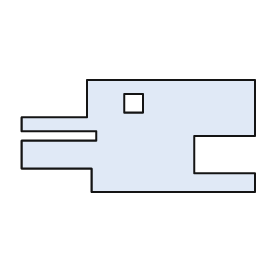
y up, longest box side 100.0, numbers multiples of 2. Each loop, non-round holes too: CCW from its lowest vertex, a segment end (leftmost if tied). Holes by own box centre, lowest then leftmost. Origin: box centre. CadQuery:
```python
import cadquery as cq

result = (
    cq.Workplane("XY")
    .moveTo(-20.0, -24.0)
    .lineTo(50.0, -24.0)
    .lineTo(50.0, -16.0)
    .lineTo(24.0, -16.0)
    .lineTo(24.0, 0.0)
    .lineTo(50.0, 0.0)
    .lineTo(50.0, 24.0)
    .lineTo(-22.0, 24.0)
    .lineTo(-22.0, 8.0)
    .lineTo(-50.0, 8.0)
    .lineTo(-50.0, 2.0)
    .lineTo(-18.0, 2.0)
    .lineTo(-18.0, -2.0)
    .lineTo(-50.0, -2.0)
    .lineTo(-50.0, -14.0)
    .lineTo(-20.0, -14.0)
    .close()
    .moveTo(-6.0, 10.0)
    .lineTo(2.0, 10.0)
    .lineTo(2.0, 18.0)
    .lineTo(-6.0, 18.0)
    .close()
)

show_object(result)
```